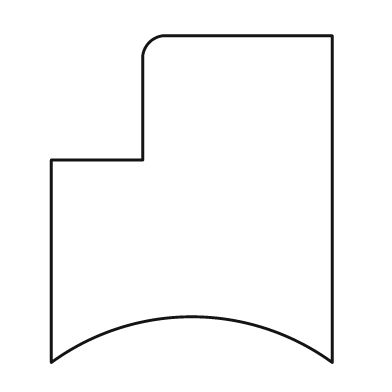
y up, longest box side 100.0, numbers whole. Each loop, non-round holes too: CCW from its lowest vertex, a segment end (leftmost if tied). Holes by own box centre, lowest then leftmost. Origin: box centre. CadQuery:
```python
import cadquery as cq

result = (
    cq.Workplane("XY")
    .moveTo(-43.0, -50.0)
    .threePointArc((0.0, -36.0), (43.0, -50.0))
    .lineTo(43.0, 50.0)
    .lineTo(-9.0, 50.0)
    .threePointArc((-13.0, 48.0), (-15.0, 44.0))
    .lineTo(-15.0, 12.0)
    .lineTo(-43.0, 12.0)
    .close()
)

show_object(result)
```